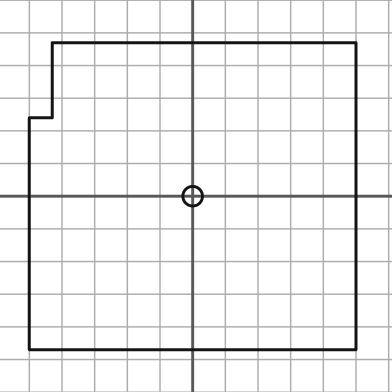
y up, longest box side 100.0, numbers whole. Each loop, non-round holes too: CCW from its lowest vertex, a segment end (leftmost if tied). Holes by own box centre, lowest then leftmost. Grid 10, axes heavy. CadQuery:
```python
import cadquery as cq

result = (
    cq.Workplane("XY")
    .moveTo(-50.0, -47.0)
    .lineTo(50.0, -47.0)
    .lineTo(50.0, 47.0)
    .lineTo(-43.0, 47.0)
    .lineTo(-43.0, 24.0)
    .lineTo(-50.0, 24.0)
    .close()
    .moveTo(0.0, 0.0)
    .circle(3.0)
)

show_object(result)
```